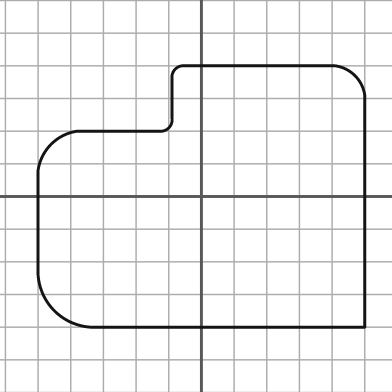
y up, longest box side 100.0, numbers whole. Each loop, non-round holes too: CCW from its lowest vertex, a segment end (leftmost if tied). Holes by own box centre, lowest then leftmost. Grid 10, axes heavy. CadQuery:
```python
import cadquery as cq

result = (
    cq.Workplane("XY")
    .moveTo(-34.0, -40.0)
    .lineTo(50.0, -40.0)
    .lineTo(50.0, 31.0)
    .threePointArc((47.0, 37.0), (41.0, 40.0))
    .lineTo(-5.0, 40.0)
    .threePointArc((-8.0, 39.0), (-9.0, 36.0))
    .lineTo(-9.0, 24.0)
    .threePointArc((-10.0, 21.0), (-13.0, 20.0))
    .lineTo(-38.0, 20.0)
    .threePointArc((-46.0, 16.0), (-50.0, 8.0))
    .lineTo(-50.0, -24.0)
    .threePointArc((-45.0, -35.0), (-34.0, -40.0))
    .close()
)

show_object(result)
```